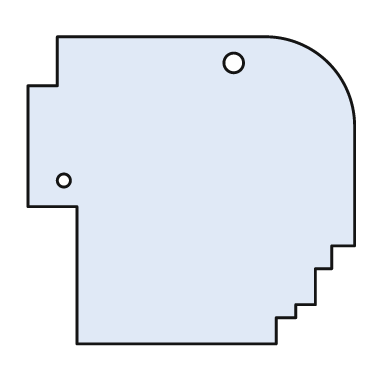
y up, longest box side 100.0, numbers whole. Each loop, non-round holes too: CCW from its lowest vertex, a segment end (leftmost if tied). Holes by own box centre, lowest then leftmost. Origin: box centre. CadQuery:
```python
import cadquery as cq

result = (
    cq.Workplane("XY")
    .moveTo(-35.0, -47.0)
    .lineTo(26.0, -47.0)
    .lineTo(26.0, -39.0)
    .lineTo(32.0, -39.0)
    .lineTo(32.0, -35.0)
    .lineTo(38.0, -35.0)
    .lineTo(38.0, -24.0)
    .lineTo(43.0, -24.0)
    .lineTo(43.0, -17.0)
    .lineTo(50.0, -17.0)
    .lineTo(50.0, 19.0)
    .threePointArc((42.0, 39.0), (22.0, 47.0))
    .lineTo(-41.0, 47.0)
    .lineTo(-41.0, 32.0)
    .lineTo(-50.0, 32.0)
    .lineTo(-50.0, -5.0)
    .lineTo(-35.0, -5.0)
    .close()
    .moveTo(-39.0, 3.0)
    .circle(2.0)
    .moveTo(13.0, 39.0)
    .circle(3.0)
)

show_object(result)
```